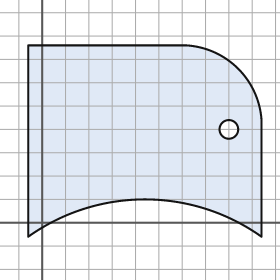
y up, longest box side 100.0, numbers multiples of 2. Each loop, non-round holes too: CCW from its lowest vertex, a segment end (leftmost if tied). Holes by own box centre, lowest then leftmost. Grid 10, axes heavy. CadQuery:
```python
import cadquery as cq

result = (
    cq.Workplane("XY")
    .moveTo(-6.0, -6.0)
    .threePointArc((44.0, 10.0), (94.0, -6.0))
    .lineTo(94.0, 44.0)
    .threePointArc((84.0, 66.0), (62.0, 76.0))
    .lineTo(-6.0, 76.0)
    .close()
    .moveTo(80.0, 40.0)
    .circle(4.0)
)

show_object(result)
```